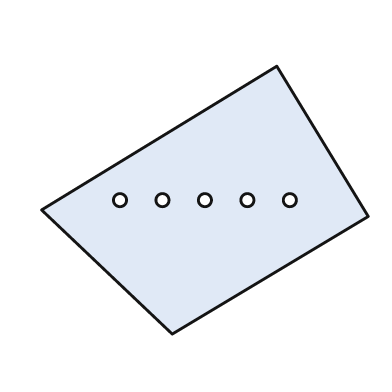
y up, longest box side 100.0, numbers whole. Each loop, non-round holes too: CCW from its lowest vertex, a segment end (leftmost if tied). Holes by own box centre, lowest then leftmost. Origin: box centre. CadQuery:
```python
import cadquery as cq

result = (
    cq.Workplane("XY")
    .moveTo(-10.0, -41.0)
    .lineTo(50.0, -5.0)
    .lineTo(22.0, 41.0)
    .lineTo(-50.0, -3.0)
    .close()
    .moveTo(-26.0, 0.0)
    .circle(2.0)
    .moveTo(-13.0, 0.0)
    .circle(2.0)
    .moveTo(0.0, 0.0)
    .circle(2.0)
    .moveTo(13.0, 0.0)
    .circle(2.0)
    .moveTo(26.0, 0.0)
    .circle(2.0)
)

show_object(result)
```